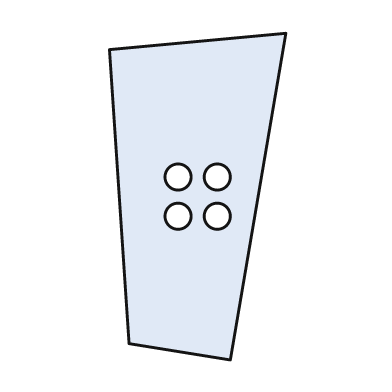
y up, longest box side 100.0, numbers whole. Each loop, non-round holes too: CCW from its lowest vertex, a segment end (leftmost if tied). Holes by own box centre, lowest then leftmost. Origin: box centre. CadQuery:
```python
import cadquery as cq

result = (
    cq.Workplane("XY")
    .moveTo(10.0, -50.0)
    .lineTo(27.0, 50.0)
    .lineTo(-27.0, 45.0)
    .lineTo(-21.0, -45.0)
    .close()
    .moveTo(-6.0, -6.0)
    .circle(4.0)
    .moveTo(6.0, -6.0)
    .circle(4.0)
    .moveTo(-6.0, 6.0)
    .circle(4.0)
    .moveTo(6.0, 6.0)
    .circle(4.0)
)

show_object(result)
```